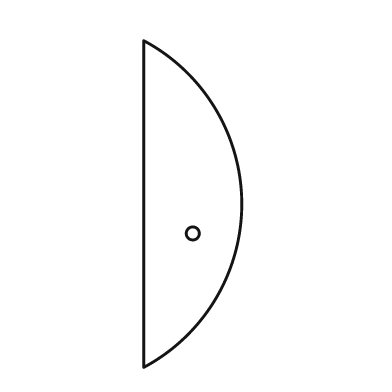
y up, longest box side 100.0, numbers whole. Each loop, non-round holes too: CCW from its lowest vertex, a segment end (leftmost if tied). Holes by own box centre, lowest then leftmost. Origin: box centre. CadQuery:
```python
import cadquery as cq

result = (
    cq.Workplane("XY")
    .moveTo(-15.0, -50.0)
    .threePointArc((15.0, 0.0), (-15.0, 50.0))
    .close()
    .moveTo(0.0, -9.0)
    .circle(2.0)
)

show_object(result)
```